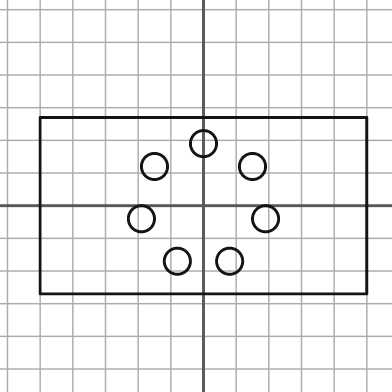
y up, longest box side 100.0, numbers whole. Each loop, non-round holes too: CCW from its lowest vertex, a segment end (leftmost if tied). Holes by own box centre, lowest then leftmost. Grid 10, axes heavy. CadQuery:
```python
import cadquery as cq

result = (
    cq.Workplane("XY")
    .moveTo(-50.0, -27.0)
    .lineTo(50.0, -27.0)
    .lineTo(50.0, 27.0)
    .lineTo(-50.0, 27.0)
    .close()
    .moveTo(-8.0, -17.0)
    .circle(4.0)
    .moveTo(8.0, -17.0)
    .circle(4.0)
    .moveTo(-19.0, -4.0)
    .circle(4.0)
    .moveTo(19.0, -4.0)
    .circle(4.0)
    .moveTo(-15.0, 12.0)
    .circle(4.0)
    .moveTo(15.0, 12.0)
    .circle(4.0)
    .moveTo(0.0, 19.0)
    .circle(4.0)
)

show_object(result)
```